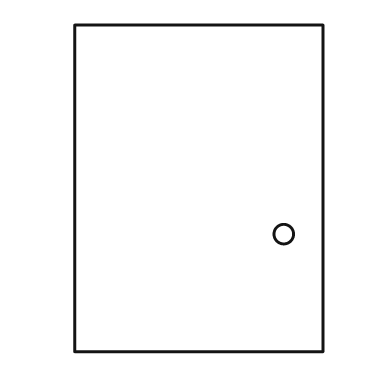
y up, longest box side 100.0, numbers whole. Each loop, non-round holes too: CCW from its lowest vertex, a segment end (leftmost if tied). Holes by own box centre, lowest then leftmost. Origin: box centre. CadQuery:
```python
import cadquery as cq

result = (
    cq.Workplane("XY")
    .moveTo(-38.0, -50.0)
    .lineTo(38.0, -50.0)
    .lineTo(38.0, 50.0)
    .lineTo(-38.0, 50.0)
    .close()
    .moveTo(26.0, -14.0)
    .circle(3.0)
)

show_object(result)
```